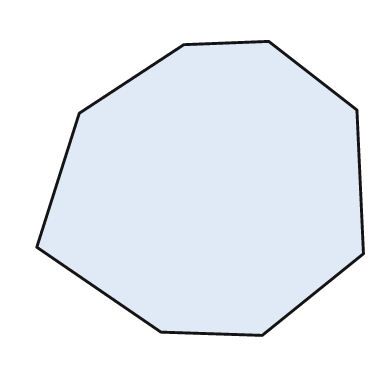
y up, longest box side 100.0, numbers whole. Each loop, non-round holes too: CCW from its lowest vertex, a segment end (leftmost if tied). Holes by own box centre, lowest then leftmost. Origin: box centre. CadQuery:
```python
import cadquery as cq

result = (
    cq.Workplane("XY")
    .moveTo(19.0, -45.0)
    .lineTo(50.0, -20.0)
    .lineTo(48.0, 24.0)
    .lineTo(21.0, 45.0)
    .lineTo(-5.0, 44.0)
    .lineTo(-37.0, 23.0)
    .lineTo(-50.0, -18.0)
    .lineTo(-12.0, -44.0)
    .close()
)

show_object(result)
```